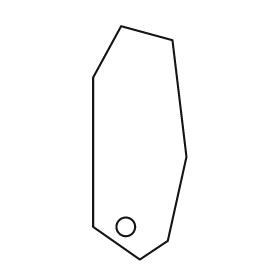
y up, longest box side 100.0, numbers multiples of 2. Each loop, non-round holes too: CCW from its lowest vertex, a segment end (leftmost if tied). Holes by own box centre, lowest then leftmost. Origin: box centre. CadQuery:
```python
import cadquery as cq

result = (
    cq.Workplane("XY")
    .moveTo(0.0, -50.0)
    .lineTo(12.0, -42.0)
    .lineTo(20.0, -6.0)
    .lineTo(14.0, 44.0)
    .lineTo(-8.0, 50.0)
    .lineTo(-20.0, 28.0)
    .lineTo(-20.0, -36.0)
    .close()
    .moveTo(-6.0, -36.0)
    .circle(4.0)
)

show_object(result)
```